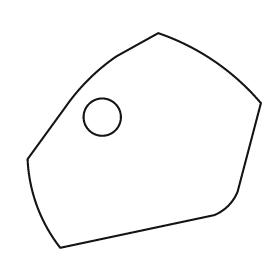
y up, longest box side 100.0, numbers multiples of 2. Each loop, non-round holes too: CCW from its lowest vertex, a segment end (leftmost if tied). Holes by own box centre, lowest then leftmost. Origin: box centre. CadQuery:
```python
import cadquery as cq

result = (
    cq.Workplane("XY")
    .moveTo(-36.0, -46.0)
    .lineTo(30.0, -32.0)
    .threePointArc((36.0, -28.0), (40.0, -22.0))
    .lineTo(50.0, 16.0)
    .threePointArc((30.0, 34.0), (6.0, 46.0))
    .lineTo(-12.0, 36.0)
    .threePointArc((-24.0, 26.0), (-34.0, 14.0))
    .lineTo(-50.0, -8.0)
    .threePointArc((-46.0, -28.0), (-36.0, -46.0))
    .close()
    .moveTo(-18.0, 10.0)
    .circle(8.0)
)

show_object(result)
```